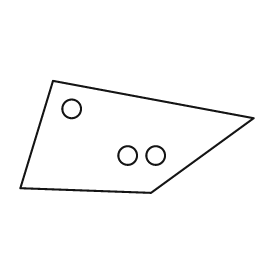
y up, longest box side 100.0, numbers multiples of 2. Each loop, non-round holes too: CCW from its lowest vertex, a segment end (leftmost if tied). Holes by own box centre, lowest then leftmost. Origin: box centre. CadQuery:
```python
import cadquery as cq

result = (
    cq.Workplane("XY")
    .moveTo(6.0, -24.0)
    .lineTo(50.0, 8.0)
    .lineTo(-36.0, 24.0)
    .lineTo(-50.0, -22.0)
    .close()
    .moveTo(-4.0, -8.0)
    .circle(4.0)
    .moveTo(8.0, -8.0)
    .circle(4.0)
    .moveTo(-28.0, 12.0)
    .circle(4.0)
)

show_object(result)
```